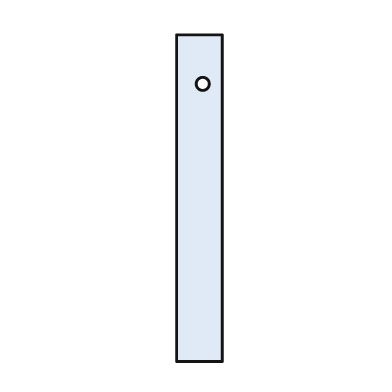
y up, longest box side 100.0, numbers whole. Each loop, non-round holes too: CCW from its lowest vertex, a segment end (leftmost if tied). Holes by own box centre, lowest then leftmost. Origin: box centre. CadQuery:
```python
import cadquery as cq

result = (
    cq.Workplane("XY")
    .moveTo(-7.0, -50.0)
    .lineTo(7.0, -50.0)
    .lineTo(7.0, 50.0)
    .lineTo(-7.0, 50.0)
    .close()
    .moveTo(1.0, 35.0)
    .circle(2.0)
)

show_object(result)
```